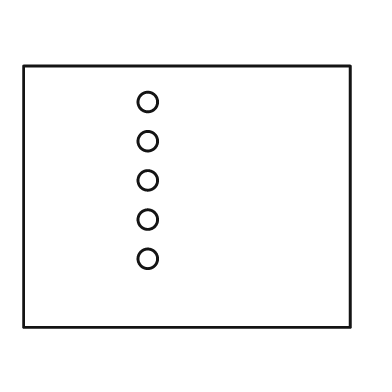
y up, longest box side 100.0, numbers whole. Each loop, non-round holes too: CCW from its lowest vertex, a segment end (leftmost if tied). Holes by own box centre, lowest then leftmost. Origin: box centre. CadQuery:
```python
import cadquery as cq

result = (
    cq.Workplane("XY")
    .moveTo(-50.0, -40.0)
    .lineTo(50.0, -40.0)
    .lineTo(50.0, 40.0)
    .lineTo(-50.0, 40.0)
    .close()
    .moveTo(-12.0, -19.0)
    .circle(3.0)
    .moveTo(-12.0, -7.0)
    .circle(3.0)
    .moveTo(-12.0, 5.0)
    .circle(3.0)
    .moveTo(-12.0, 17.0)
    .circle(3.0)
    .moveTo(-12.0, 29.0)
    .circle(3.0)
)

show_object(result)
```